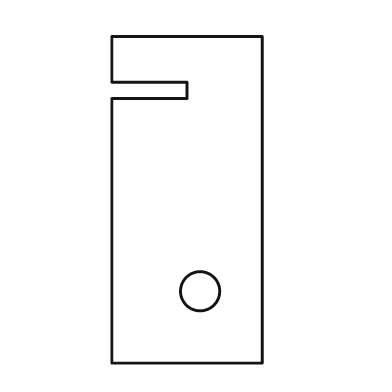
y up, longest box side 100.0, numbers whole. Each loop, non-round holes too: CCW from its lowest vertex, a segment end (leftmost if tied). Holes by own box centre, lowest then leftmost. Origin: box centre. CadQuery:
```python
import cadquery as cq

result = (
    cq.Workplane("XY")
    .moveTo(-23.0, -50.0)
    .lineTo(23.0, -50.0)
    .lineTo(23.0, 50.0)
    .lineTo(-23.0, 50.0)
    .lineTo(-23.0, 36.0)
    .lineTo(0.0, 36.0)
    .lineTo(0.0, 31.0)
    .lineTo(-23.0, 31.0)
    .close()
    .moveTo(4.0, -28.0)
    .circle(6.0)
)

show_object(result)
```